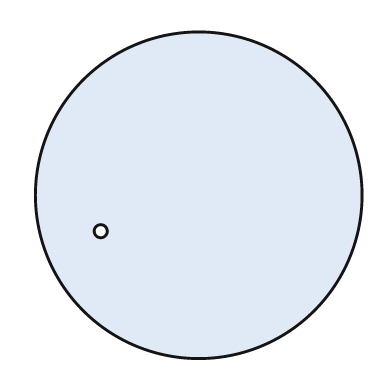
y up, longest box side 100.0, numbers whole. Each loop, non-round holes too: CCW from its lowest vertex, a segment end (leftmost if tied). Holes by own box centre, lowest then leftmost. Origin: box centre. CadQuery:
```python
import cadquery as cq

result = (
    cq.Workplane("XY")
    .moveTo(0.0, 0.0)
    .circle(50.0)
    .moveTo(-30.0, -11.0)
    .circle(2.0)
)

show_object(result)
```